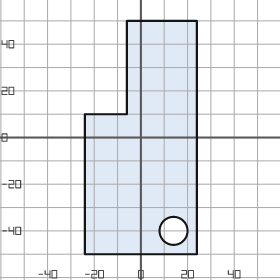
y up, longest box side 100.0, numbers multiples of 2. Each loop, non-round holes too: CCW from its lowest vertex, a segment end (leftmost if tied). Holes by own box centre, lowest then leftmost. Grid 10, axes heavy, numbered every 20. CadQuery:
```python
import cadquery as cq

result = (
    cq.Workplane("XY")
    .moveTo(-24.0, -50.0)
    .lineTo(24.0, -50.0)
    .lineTo(24.0, 50.0)
    .lineTo(-6.0, 50.0)
    .lineTo(-6.0, 10.0)
    .lineTo(-24.0, 10.0)
    .close()
    .moveTo(14.0, -40.0)
    .circle(6.0)
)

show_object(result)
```